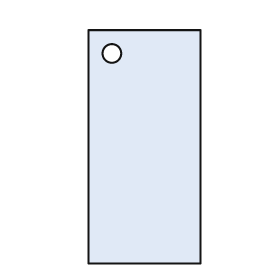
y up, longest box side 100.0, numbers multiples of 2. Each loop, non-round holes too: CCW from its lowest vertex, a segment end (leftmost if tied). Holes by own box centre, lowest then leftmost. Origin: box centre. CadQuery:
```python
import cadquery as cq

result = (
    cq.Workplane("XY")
    .moveTo(-24.0, -50.0)
    .lineTo(24.0, -50.0)
    .lineTo(24.0, 50.0)
    .lineTo(-24.0, 50.0)
    .close()
    .moveTo(-14.0, 40.0)
    .circle(4.0)
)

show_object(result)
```